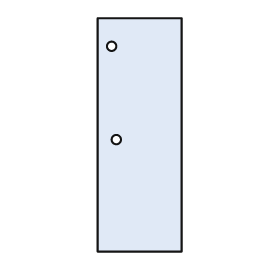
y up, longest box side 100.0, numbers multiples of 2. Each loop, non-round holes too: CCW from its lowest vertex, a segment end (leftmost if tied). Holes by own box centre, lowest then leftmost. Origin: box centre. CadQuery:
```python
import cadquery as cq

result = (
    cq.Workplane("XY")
    .moveTo(-18.0, -50.0)
    .lineTo(18.0, -50.0)
    .lineTo(18.0, 50.0)
    .lineTo(-18.0, 50.0)
    .close()
    .moveTo(-10.0, -2.0)
    .circle(2.0)
    .moveTo(-12.0, 38.0)
    .circle(2.0)
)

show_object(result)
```